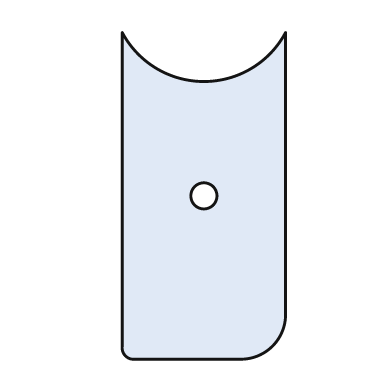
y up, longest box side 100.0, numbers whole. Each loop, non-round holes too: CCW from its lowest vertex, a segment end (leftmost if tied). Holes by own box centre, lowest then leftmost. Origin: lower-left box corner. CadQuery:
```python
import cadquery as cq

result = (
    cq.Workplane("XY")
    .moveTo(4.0, 0.0)
    .lineTo(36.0, 0.0)
    .threePointArc((46.0, 4.0), (50.0, 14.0))
    .lineTo(50.0, 100.0)
    .threePointArc((25.0, 85.0), (0.0, 100.0))
    .lineTo(0.0, 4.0)
    .threePointArc((1.0, 1.0), (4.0, 0.0))
    .close()
    .moveTo(25.0, 50.0)
    .circle(4.0)
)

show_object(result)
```